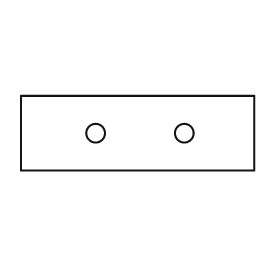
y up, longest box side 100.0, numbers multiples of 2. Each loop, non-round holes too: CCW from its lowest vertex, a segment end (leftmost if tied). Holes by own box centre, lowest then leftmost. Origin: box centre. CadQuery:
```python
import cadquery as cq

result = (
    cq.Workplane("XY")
    .moveTo(-50.0, -16.0)
    .lineTo(50.0, -16.0)
    .lineTo(50.0, 16.0)
    .lineTo(-50.0, 16.0)
    .close()
    .moveTo(-18.0, 0.0)
    .circle(4.0)
    .moveTo(20.0, 0.0)
    .circle(4.0)
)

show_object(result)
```